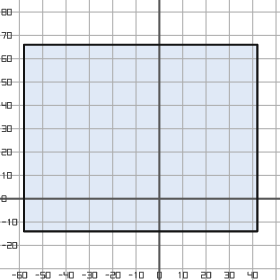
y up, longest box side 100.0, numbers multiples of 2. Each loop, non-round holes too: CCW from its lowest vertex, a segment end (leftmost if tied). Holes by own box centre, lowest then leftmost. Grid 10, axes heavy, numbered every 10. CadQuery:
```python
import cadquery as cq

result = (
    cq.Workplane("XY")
    .moveTo(-58.0, -14.0)
    .lineTo(42.0, -14.0)
    .lineTo(42.0, 66.0)
    .lineTo(-58.0, 66.0)
    .close()
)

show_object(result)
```